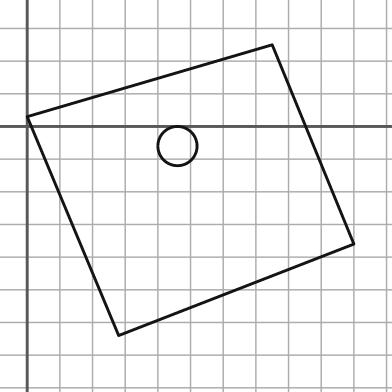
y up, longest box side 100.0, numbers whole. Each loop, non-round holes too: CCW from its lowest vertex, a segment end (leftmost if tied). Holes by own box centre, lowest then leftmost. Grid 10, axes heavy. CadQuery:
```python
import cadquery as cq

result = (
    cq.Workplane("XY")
    .moveTo(28.0, -64.0)
    .lineTo(100.0, -36.0)
    .lineTo(75.0, 25.0)
    .lineTo(0.0, 3.0)
    .close()
    .moveTo(46.0, -6.0)
    .circle(6.0)
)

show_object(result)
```